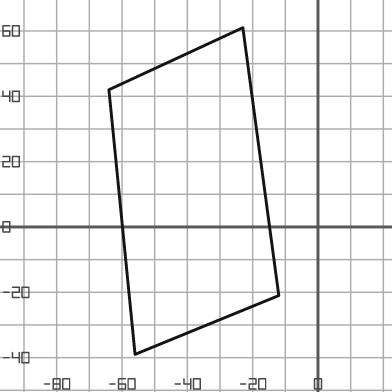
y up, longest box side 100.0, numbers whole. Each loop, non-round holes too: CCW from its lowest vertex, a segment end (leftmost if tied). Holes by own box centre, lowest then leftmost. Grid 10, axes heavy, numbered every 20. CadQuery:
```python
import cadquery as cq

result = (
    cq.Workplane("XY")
    .moveTo(-56.0, -39.0)
    .lineTo(-12.0, -21.0)
    .lineTo(-23.0, 61.0)
    .lineTo(-64.0, 42.0)
    .close()
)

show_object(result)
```